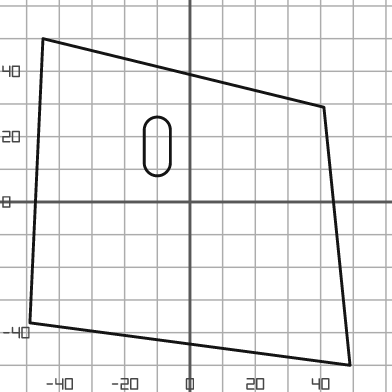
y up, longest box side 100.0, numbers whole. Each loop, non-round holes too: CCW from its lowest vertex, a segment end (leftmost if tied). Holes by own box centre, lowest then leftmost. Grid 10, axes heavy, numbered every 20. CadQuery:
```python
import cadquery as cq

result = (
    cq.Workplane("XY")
    .moveTo(49.0, -50.0)
    .lineTo(41.0, 29.0)
    .lineTo(-45.0, 50.0)
    .lineTo(-49.0, -37.0)
    .close()
    .moveTo(-14.0, 12.0)
    .threePointArc((-10.0, 8.0), (-6.0, 12.0))
    .lineTo(-6.0, 22.0)
    .threePointArc((-10.0, 26.0), (-14.0, 22.0))
    .close()
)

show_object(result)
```